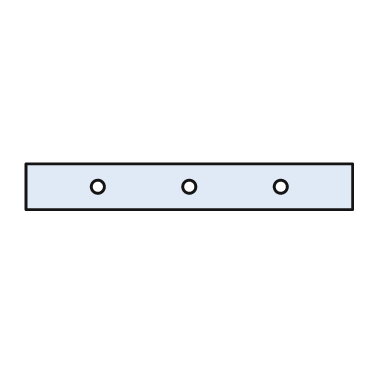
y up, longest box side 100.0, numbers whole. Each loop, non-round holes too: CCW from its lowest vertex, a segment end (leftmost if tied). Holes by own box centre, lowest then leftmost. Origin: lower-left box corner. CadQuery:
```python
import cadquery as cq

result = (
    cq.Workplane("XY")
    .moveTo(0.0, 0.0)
    .lineTo(100.0, 0.0)
    .lineTo(100.0, 14.0)
    .lineTo(0.0, 14.0)
    .close()
    .moveTo(22.0, 7.0)
    .circle(2.0)
    .moveTo(50.0, 7.0)
    .circle(2.0)
    .moveTo(78.0, 7.0)
    .circle(2.0)
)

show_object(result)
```